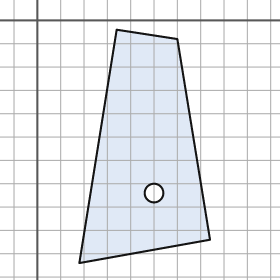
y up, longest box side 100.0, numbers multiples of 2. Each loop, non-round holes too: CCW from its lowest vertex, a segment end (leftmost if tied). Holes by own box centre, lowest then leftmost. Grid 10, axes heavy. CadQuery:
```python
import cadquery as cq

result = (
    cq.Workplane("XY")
    .moveTo(18.0, -104.0)
    .lineTo(74.0, -94.0)
    .lineTo(60.0, -8.0)
    .lineTo(34.0, -4.0)
    .close()
    .moveTo(50.0, -74.0)
    .circle(4.0)
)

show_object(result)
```